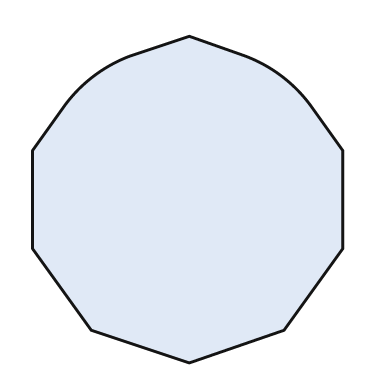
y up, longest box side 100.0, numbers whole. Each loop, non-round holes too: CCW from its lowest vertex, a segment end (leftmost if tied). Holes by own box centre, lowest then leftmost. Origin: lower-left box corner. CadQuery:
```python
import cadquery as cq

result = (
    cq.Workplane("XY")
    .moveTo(48.0, 0.0)
    .lineTo(77.0, 10.0)
    .lineTo(95.0, 35.0)
    .lineTo(95.0, 65.0)
    .lineTo(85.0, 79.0)
    .threePointArc((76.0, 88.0), (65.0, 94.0))
    .lineTo(48.0, 100.0)
    .lineTo(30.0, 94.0)
    .threePointArc((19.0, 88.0), (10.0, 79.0))
    .lineTo(0.0, 65.0)
    .lineTo(0.0, 35.0)
    .lineTo(18.0, 10.0)
    .close()
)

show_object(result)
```